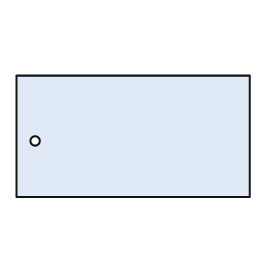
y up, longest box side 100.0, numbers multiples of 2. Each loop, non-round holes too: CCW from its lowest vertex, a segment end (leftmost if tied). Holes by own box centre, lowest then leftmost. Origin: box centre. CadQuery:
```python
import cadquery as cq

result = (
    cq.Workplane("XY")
    .moveTo(-50.0, -26.0)
    .lineTo(50.0, -26.0)
    .lineTo(50.0, 26.0)
    .lineTo(-50.0, 26.0)
    .close()
    .moveTo(-42.0, -2.0)
    .circle(2.0)
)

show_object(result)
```